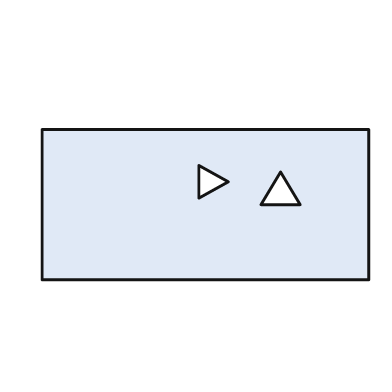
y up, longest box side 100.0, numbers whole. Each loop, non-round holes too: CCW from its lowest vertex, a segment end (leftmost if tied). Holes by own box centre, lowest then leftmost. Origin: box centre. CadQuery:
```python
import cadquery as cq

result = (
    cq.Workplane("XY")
    .moveTo(-50.0, -23.0)
    .lineTo(50.0, -23.0)
    .lineTo(50.0, 23.0)
    .lineTo(-50.0, 23.0)
    .close()
    .moveTo(17.0, 0.0)
    .lineTo(29.0, 0.0)
    .lineTo(23.0, 10.0)
    .close()
    .moveTo(-2.0, 2.0)
    .lineTo(7.0, 7.0)
    .lineTo(-2.0, 12.0)
    .close()
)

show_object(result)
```